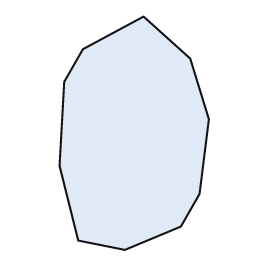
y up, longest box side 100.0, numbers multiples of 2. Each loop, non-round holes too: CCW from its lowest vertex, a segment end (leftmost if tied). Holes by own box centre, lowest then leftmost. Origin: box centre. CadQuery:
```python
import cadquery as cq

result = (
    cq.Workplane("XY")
    .moveTo(-4.0, -50.0)
    .lineTo(20.0, -40.0)
    .lineTo(28.0, -26.0)
    .lineTo(32.0, 6.0)
    .lineTo(24.0, 32.0)
    .lineTo(4.0, 50.0)
    .lineTo(-22.0, 36.0)
    .lineTo(-30.0, 22.0)
    .lineTo(-32.0, -14.0)
    .lineTo(-24.0, -46.0)
    .close()
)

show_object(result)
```